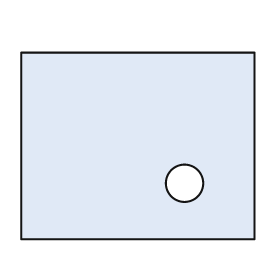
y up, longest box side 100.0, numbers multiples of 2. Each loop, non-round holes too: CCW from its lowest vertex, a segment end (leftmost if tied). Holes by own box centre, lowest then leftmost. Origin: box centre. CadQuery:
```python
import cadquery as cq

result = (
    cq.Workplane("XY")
    .moveTo(-50.0, -40.0)
    .lineTo(50.0, -40.0)
    .lineTo(50.0, 40.0)
    .lineTo(-50.0, 40.0)
    .close()
    .moveTo(20.0, -16.0)
    .circle(8.0)
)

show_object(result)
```